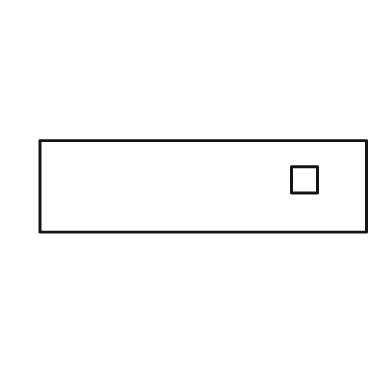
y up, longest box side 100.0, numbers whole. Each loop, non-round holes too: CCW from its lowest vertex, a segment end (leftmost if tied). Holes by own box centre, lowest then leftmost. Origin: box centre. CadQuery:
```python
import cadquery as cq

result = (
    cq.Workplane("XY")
    .moveTo(-50.0, -14.0)
    .lineTo(50.0, -14.0)
    .lineTo(50.0, 14.0)
    .lineTo(-50.0, 14.0)
    .close()
    .moveTo(27.0, -2.0)
    .lineTo(35.0, -2.0)
    .lineTo(35.0, 6.0)
    .lineTo(27.0, 6.0)
    .close()
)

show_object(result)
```